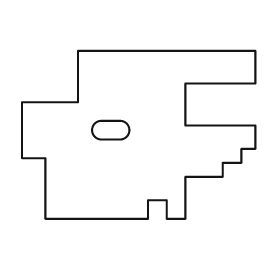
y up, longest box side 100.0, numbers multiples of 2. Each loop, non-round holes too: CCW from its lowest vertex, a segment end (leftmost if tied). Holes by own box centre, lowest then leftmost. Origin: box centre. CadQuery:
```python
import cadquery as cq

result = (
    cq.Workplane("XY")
    .moveTo(-40.0, -36.0)
    .lineTo(4.0, -36.0)
    .lineTo(4.0, -28.0)
    .lineTo(12.0, -28.0)
    .lineTo(12.0, -36.0)
    .lineTo(20.0, -36.0)
    .lineTo(20.0, -18.0)
    .lineTo(36.0, -18.0)
    .lineTo(36.0, -12.0)
    .lineTo(44.0, -12.0)
    .lineTo(44.0, -6.0)
    .lineTo(50.0, -6.0)
    .lineTo(50.0, 4.0)
    .lineTo(20.0, 4.0)
    .lineTo(20.0, 22.0)
    .lineTo(50.0, 22.0)
    .lineTo(50.0, 36.0)
    .lineTo(-26.0, 36.0)
    .lineTo(-26.0, 14.0)
    .lineTo(-50.0, 14.0)
    .lineTo(-50.0, -10.0)
    .lineTo(-40.0, -10.0)
    .close()
    .moveTo(-16.0, -2.0)
    .lineTo(-8.0, -2.0)
    .threePointArc((-4.0, 2.0), (-8.0, 6.0))
    .lineTo(-16.0, 6.0)
    .threePointArc((-20.0, 2.0), (-16.0, -2.0))
    .close()
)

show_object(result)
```